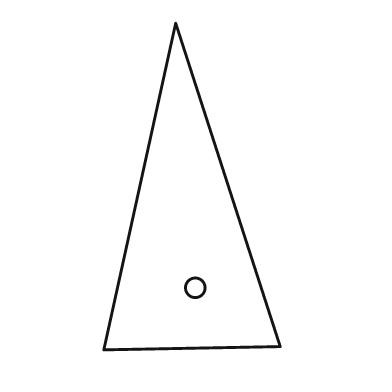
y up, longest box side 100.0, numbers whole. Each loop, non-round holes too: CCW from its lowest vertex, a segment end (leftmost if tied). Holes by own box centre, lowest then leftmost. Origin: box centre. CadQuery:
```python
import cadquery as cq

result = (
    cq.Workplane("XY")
    .moveTo(-27.0, -50.0)
    .lineTo(27.0, -49.0)
    .lineTo(-5.0, 50.0)
    .close()
    .moveTo(1.0, -31.0)
    .circle(3.0)
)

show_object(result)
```